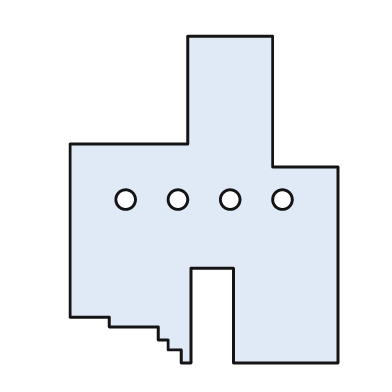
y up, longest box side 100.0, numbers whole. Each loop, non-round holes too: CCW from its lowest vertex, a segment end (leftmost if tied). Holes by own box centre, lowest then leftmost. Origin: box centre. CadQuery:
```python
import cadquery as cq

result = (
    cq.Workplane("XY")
    .moveTo(-7.0, -50.0)
    .lineTo(-4.0, -50.0)
    .lineTo(-4.0, -21.0)
    .lineTo(9.0, -21.0)
    .lineTo(9.0, -50.0)
    .lineTo(41.0, -50.0)
    .lineTo(41.0, 10.0)
    .lineTo(21.0, 10.0)
    .lineTo(21.0, 50.0)
    .lineTo(-5.0, 50.0)
    .lineTo(-5.0, 17.0)
    .lineTo(-41.0, 17.0)
    .lineTo(-41.0, -36.0)
    .lineTo(-29.0, -36.0)
    .lineTo(-29.0, -39.0)
    .lineTo(-14.0, -39.0)
    .lineTo(-14.0, -43.0)
    .lineTo(-11.0, -43.0)
    .lineTo(-11.0, -46.0)
    .lineTo(-7.0, -46.0)
    .close()
    .moveTo(-24.0, 0.0)
    .circle(3.0)
    .moveTo(-8.0, 0.0)
    .circle(3.0)
    .moveTo(8.0, 0.0)
    .circle(3.0)
    .moveTo(24.0, 0.0)
    .circle(3.0)
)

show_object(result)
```